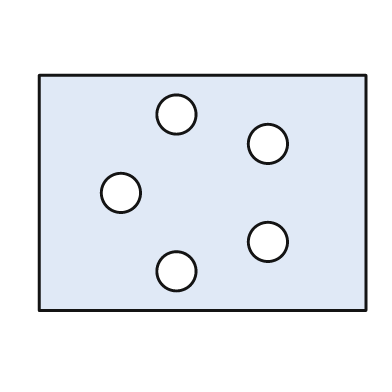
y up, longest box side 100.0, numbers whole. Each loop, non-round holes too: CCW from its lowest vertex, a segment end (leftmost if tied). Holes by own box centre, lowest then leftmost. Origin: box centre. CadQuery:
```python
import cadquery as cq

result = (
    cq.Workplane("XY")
    .moveTo(-50.0, -36.0)
    .lineTo(50.0, -36.0)
    .lineTo(50.0, 36.0)
    .lineTo(-50.0, 36.0)
    .close()
    .moveTo(-8.0, -24.0)
    .circle(6.0)
    .moveTo(20.0, -15.0)
    .circle(6.0)
    .moveTo(-25.0, 0.0)
    .circle(6.0)
    .moveTo(20.0, 15.0)
    .circle(6.0)
    .moveTo(-8.0, 24.0)
    .circle(6.0)
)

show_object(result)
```